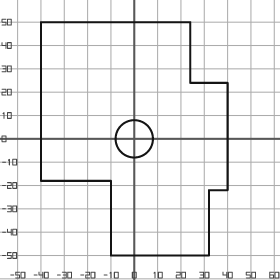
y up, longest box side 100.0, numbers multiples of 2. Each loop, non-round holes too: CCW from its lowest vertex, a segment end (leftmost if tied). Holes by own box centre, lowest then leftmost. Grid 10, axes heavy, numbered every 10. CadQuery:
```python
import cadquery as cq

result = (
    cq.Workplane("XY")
    .moveTo(-10.0, -50.0)
    .lineTo(32.0, -50.0)
    .lineTo(32.0, -22.0)
    .lineTo(40.0, -22.0)
    .lineTo(40.0, 24.0)
    .lineTo(24.0, 24.0)
    .lineTo(24.0, 50.0)
    .lineTo(-40.0, 50.0)
    .lineTo(-40.0, -18.0)
    .lineTo(-10.0, -18.0)
    .close()
    .moveTo(0.0, 0.0)
    .circle(8.0)
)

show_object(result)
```